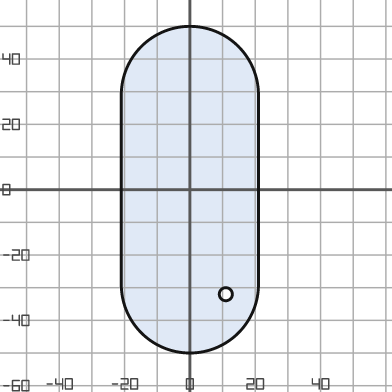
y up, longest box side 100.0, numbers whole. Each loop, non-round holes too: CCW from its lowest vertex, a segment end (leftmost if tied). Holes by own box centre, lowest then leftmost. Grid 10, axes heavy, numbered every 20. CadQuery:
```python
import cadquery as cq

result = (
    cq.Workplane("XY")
    .moveTo(-21.0, -29.0)
    .threePointArc((0.0, -50.0), (21.0, -29.0))
    .lineTo(21.0, 29.0)
    .threePointArc((0.0, 50.0), (-21.0, 29.0))
    .close()
    .moveTo(11.0, -32.0)
    .circle(2.0)
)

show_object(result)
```